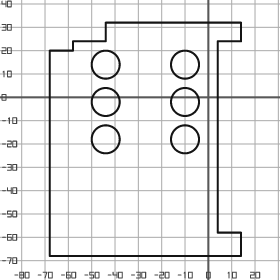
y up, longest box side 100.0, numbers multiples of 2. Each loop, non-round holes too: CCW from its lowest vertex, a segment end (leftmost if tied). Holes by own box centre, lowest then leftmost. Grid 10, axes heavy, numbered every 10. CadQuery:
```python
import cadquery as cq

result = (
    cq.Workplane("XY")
    .moveTo(-68.0, -68.0)
    .lineTo(14.0, -68.0)
    .lineTo(14.0, -58.0)
    .lineTo(4.0, -58.0)
    .lineTo(4.0, 24.0)
    .lineTo(14.0, 24.0)
    .lineTo(14.0, 32.0)
    .lineTo(-44.0, 32.0)
    .lineTo(-44.0, 24.0)
    .lineTo(-58.0, 24.0)
    .lineTo(-58.0, 20.0)
    .lineTo(-68.0, 20.0)
    .close()
    .moveTo(-44.0, -18.0)
    .circle(6.0)
    .moveTo(-10.0, -18.0)
    .circle(6.0)
    .moveTo(-44.0, -2.0)
    .circle(6.0)
    .moveTo(-10.0, -2.0)
    .circle(6.0)
    .moveTo(-44.0, 14.0)
    .circle(6.0)
    .moveTo(-10.0, 14.0)
    .circle(6.0)
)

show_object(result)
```